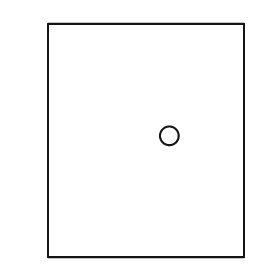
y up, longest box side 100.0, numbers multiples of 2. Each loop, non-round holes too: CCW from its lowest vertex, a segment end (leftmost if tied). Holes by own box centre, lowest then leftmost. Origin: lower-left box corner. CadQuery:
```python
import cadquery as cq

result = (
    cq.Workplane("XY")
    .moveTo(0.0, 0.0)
    .lineTo(84.0, 0.0)
    .lineTo(84.0, 100.0)
    .lineTo(0.0, 100.0)
    .close()
    .moveTo(52.0, 52.0)
    .circle(4.0)
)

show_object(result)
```